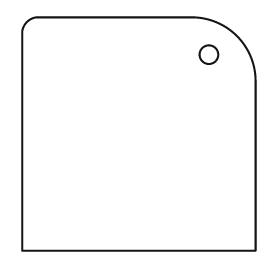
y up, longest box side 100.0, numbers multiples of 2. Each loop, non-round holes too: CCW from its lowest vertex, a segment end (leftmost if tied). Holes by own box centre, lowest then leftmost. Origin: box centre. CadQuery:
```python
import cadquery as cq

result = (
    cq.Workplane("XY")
    .moveTo(-50.0, -50.0)
    .lineTo(50.0, -50.0)
    .lineTo(50.0, 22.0)
    .threePointArc((42.0, 42.0), (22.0, 50.0))
    .lineTo(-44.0, 50.0)
    .threePointArc((-48.0, 48.0), (-50.0, 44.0))
    .close()
    .moveTo(30.0, 34.0)
    .circle(4.0)
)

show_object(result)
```